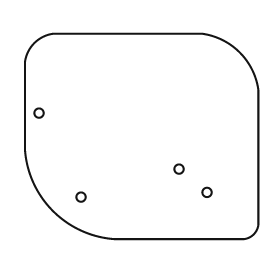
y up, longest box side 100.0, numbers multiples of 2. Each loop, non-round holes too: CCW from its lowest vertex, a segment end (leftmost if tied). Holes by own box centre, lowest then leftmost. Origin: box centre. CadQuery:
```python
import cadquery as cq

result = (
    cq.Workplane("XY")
    .moveTo(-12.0, -44.0)
    .lineTo(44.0, -44.0)
    .threePointArc((48.0, -42.0), (50.0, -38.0))
    .lineTo(50.0, 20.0)
    .threePointArc((42.0, 36.0), (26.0, 44.0))
    .lineTo(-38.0, 44.0)
    .threePointArc((-46.0, 40.0), (-50.0, 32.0))
    .lineTo(-50.0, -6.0)
    .threePointArc((-38.0, -32.0), (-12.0, -44.0))
    .close()
    .moveTo(-26.0, -26.0)
    .circle(2.0)
    .moveTo(28.0, -24.0)
    .circle(2.0)
    .moveTo(16.0, -14.0)
    .circle(2.0)
    .moveTo(-44.0, 10.0)
    .circle(2.0)
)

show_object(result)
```